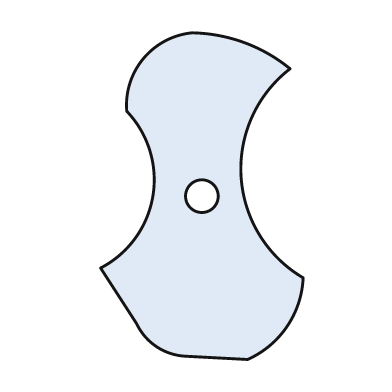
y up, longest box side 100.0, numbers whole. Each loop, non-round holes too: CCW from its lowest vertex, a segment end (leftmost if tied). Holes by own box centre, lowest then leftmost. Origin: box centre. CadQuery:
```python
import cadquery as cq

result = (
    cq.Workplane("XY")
    .moveTo(14.0, -50.0)
    .threePointArc((26.0, -40.0), (31.0, -25.0))
    .threePointArc((12.0, 6.0), (27.0, 39.0))
    .threePointArc((13.0, 47.0), (-3.0, 50.0))
    .threePointArc((-18.0, 42.0), (-23.0, 26.0))
    .threePointArc((-15.0, 0.0), (-31.0, -22.0))
    .lineTo(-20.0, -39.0)
    .threePointArc((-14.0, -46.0), (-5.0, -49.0))
    .close()
    .moveTo(0.0, 0.0)
    .circle(5.0)
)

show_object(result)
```